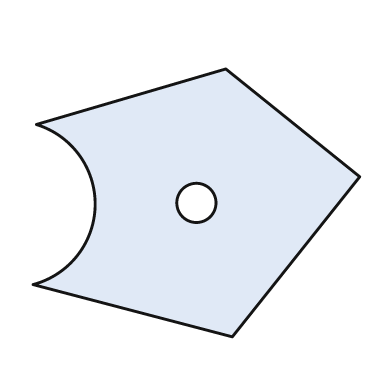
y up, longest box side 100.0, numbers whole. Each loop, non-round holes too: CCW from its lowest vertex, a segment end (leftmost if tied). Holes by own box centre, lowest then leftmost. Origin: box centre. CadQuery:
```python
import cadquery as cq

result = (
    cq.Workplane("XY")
    .moveTo(11.0, -41.0)
    .lineTo(50.0, 8.0)
    .lineTo(9.0, 41.0)
    .lineTo(-49.0, 24.0)
    .threePointArc((-31.0, -1.0), (-50.0, -25.0))
    .close()
    .moveTo(0.0, 0.0)
    .circle(6.0)
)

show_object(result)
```